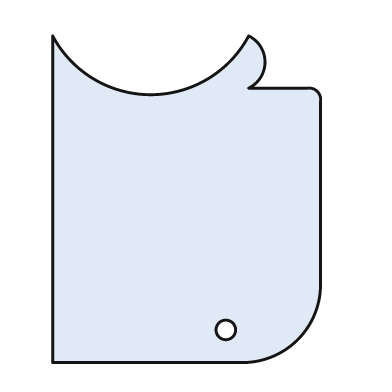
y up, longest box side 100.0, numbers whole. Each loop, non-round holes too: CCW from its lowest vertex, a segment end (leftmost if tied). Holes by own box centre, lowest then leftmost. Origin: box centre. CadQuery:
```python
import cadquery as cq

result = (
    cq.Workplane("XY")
    .moveTo(-41.0, -50.0)
    .lineTo(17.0, -50.0)
    .threePointArc((34.0, -43.0), (41.0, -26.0))
    .lineTo(41.0, 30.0)
    .threePointArc((40.0, 33.0), (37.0, 34.0))
    .lineTo(19.0, 34.0)
    .threePointArc((24.0, 42.0), (19.0, 50.0))
    .threePointArc((-11.0, 32.0), (-41.0, 50.0))
    .close()
    .moveTo(12.0, -40.0)
    .circle(3.0)
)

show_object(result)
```